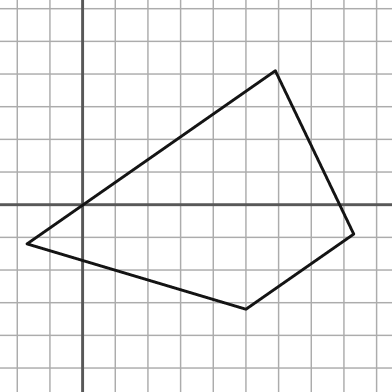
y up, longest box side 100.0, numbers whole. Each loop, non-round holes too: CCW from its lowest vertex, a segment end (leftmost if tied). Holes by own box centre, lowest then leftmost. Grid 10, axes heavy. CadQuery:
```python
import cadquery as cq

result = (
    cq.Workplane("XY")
    .moveTo(50.0, -32.0)
    .lineTo(83.0, -9.0)
    .lineTo(59.0, 41.0)
    .lineTo(-17.0, -12.0)
    .close()
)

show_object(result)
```